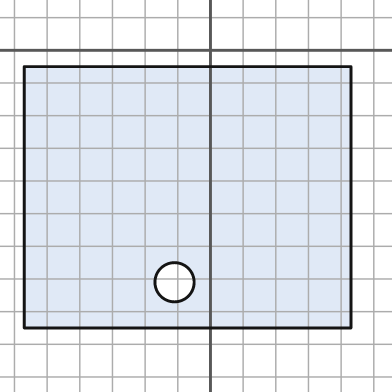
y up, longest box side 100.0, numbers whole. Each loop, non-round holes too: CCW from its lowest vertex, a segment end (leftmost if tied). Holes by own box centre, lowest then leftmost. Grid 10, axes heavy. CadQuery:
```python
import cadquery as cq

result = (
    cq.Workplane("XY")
    .moveTo(-57.0, -85.0)
    .lineTo(43.0, -85.0)
    .lineTo(43.0, -5.0)
    .lineTo(-57.0, -5.0)
    .close()
    .moveTo(-11.0, -71.0)
    .circle(6.0)
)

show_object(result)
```